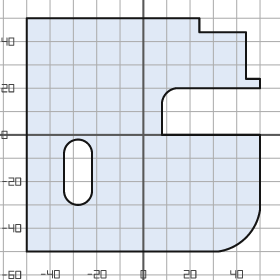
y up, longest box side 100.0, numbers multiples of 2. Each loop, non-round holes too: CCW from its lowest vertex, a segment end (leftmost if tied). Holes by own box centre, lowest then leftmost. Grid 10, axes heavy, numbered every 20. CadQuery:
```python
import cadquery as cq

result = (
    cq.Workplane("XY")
    .moveTo(-50.0, -50.0)
    .lineTo(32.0, -50.0)
    .threePointArc((44.0, -44.0), (50.0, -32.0))
    .lineTo(50.0, 0.0)
    .lineTo(8.0, 0.0)
    .lineTo(8.0, 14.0)
    .threePointArc((10.0, 18.0), (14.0, 20.0))
    .lineTo(50.0, 20.0)
    .lineTo(50.0, 24.0)
    .lineTo(44.0, 24.0)
    .lineTo(44.0, 44.0)
    .lineTo(24.0, 44.0)
    .lineTo(24.0, 50.0)
    .lineTo(-50.0, 50.0)
    .close()
    .moveTo(-34.0, -24.0)
    .threePointArc((-28.0, -30.0), (-22.0, -24.0))
    .lineTo(-22.0, -8.0)
    .threePointArc((-28.0, -2.0), (-34.0, -8.0))
    .close()
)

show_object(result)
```